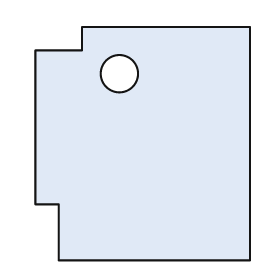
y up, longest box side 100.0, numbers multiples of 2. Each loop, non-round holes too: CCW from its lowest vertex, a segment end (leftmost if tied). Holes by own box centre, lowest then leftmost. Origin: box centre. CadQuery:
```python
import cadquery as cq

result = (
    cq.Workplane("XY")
    .moveTo(-36.0, -50.0)
    .lineTo(46.0, -50.0)
    .lineTo(46.0, 50.0)
    .lineTo(-26.0, 50.0)
    .lineTo(-26.0, 40.0)
    .lineTo(-46.0, 40.0)
    .lineTo(-46.0, -26.0)
    .lineTo(-36.0, -26.0)
    .close()
    .moveTo(-10.0, 30.0)
    .circle(8.0)
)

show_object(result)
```